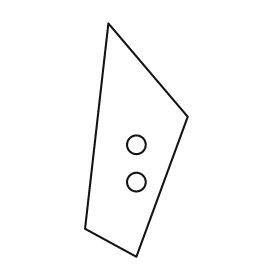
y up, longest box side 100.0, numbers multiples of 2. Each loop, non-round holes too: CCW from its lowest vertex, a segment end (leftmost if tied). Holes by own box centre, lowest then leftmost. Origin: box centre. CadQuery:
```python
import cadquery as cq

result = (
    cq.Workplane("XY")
    .moveTo(0.0, -50.0)
    .lineTo(22.0, 10.0)
    .lineTo(-12.0, 50.0)
    .lineTo(-22.0, -38.0)
    .close()
    .moveTo(0.0, -18.0)
    .circle(4.0)
    .moveTo(0.0, -2.0)
    .circle(4.0)
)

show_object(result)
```